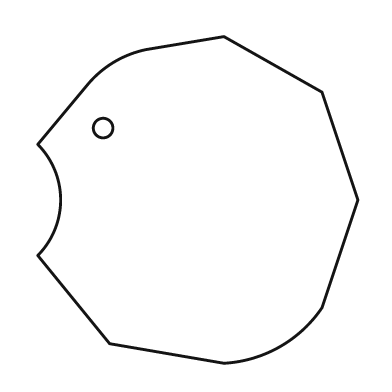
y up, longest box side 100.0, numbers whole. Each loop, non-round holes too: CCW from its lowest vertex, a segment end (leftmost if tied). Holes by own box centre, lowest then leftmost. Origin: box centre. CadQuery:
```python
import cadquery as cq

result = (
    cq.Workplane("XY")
    .moveTo(8.0, -50.0)
    .threePointArc((25.0, -45.0), (38.0, -33.0))
    .lineTo(49.0, 0.0)
    .lineTo(38.0, 33.0)
    .lineTo(8.0, 50.0)
    .lineTo(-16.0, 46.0)
    .threePointArc((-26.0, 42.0), (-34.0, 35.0))
    .lineTo(-49.0, 17.0)
    .threePointArc((-42.0, 0.0), (-49.0, -17.0))
    .lineTo(-27.0, -44.0)
    .close()
    .moveTo(-29.0, 22.0)
    .circle(3.0)
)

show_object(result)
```